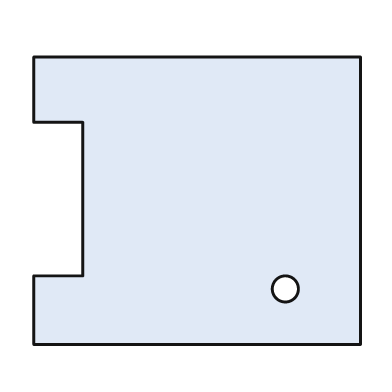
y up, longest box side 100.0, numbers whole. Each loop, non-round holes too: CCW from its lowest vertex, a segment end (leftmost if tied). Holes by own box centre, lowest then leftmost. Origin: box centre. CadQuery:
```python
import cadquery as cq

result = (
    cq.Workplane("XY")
    .moveTo(-50.0, -44.0)
    .lineTo(50.0, -44.0)
    .lineTo(50.0, 44.0)
    .lineTo(-50.0, 44.0)
    .lineTo(-50.0, 24.0)
    .lineTo(-35.0, 24.0)
    .lineTo(-35.0, -23.0)
    .lineTo(-50.0, -23.0)
    .close()
    .moveTo(27.0, -27.0)
    .circle(4.0)
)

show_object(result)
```